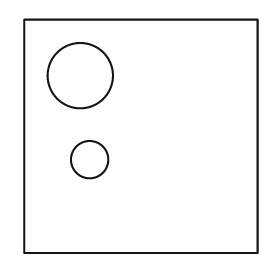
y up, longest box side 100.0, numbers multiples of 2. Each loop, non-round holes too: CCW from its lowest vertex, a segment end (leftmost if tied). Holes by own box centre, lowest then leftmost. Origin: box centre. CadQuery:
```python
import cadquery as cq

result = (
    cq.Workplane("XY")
    .moveTo(-50.0, -50.0)
    .lineTo(50.0, -50.0)
    .lineTo(50.0, 50.0)
    .lineTo(-50.0, 50.0)
    .close()
    .moveTo(-22.0, -10.0)
    .circle(8.0)
    .moveTo(-26.0, 26.0)
    .circle(14.0)
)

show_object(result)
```